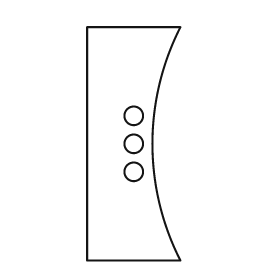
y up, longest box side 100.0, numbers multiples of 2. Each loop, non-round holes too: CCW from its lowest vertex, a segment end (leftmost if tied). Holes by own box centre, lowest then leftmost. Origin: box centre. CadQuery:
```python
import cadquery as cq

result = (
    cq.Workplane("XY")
    .moveTo(-20.0, -50.0)
    .lineTo(20.0, -50.0)
    .threePointArc((8.0, 0.0), (20.0, 50.0))
    .lineTo(-20.0, 50.0)
    .close()
    .moveTo(0.0, -12.0)
    .circle(4.0)
    .moveTo(0.0, 0.0)
    .circle(4.0)
    .moveTo(0.0, 12.0)
    .circle(4.0)
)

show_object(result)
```